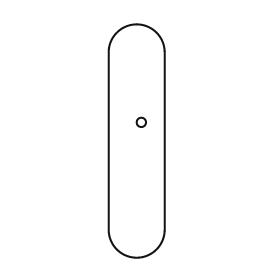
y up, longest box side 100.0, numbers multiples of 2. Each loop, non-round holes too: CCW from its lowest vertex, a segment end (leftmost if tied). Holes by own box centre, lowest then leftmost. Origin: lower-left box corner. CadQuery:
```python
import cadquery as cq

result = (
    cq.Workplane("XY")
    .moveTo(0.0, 12.0)
    .threePointArc((12.0, 0.0), (24.0, 12.0))
    .lineTo(24.0, 88.0)
    .threePointArc((12.0, 100.0), (0.0, 88.0))
    .close()
    .moveTo(14.0, 58.0)
    .circle(2.0)
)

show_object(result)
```